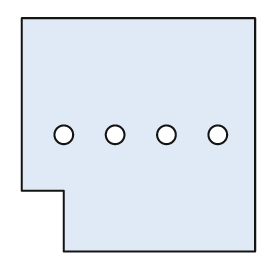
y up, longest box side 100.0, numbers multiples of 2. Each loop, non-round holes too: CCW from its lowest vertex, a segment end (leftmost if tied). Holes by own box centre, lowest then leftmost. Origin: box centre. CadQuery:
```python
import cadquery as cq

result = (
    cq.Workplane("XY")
    .moveTo(-32.0, -50.0)
    .lineTo(50.0, -50.0)
    .lineTo(50.0, 50.0)
    .lineTo(-50.0, 50.0)
    .lineTo(-50.0, -24.0)
    .lineTo(-32.0, -24.0)
    .close()
    .moveTo(-32.0, 0.0)
    .circle(4.0)
    .moveTo(-10.0, 0.0)
    .circle(4.0)
    .moveTo(12.0, 0.0)
    .circle(4.0)
    .moveTo(34.0, 0.0)
    .circle(4.0)
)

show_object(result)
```